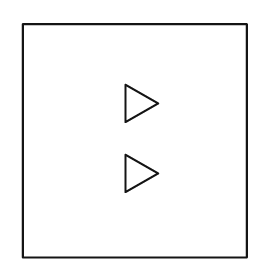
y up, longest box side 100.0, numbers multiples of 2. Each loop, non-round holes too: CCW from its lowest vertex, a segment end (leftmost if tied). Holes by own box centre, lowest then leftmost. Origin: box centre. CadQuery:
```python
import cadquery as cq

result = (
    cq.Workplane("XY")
    .moveTo(-48.0, -50.0)
    .lineTo(48.0, -50.0)
    .lineTo(48.0, 50.0)
    .lineTo(-48.0, 50.0)
    .close()
    .moveTo(-4.0, -22.0)
    .lineTo(10.0, -14.0)
    .lineTo(-4.0, -6.0)
    .close()
    .moveTo(-4.0, 8.0)
    .lineTo(10.0, 16.0)
    .lineTo(-4.0, 24.0)
    .close()
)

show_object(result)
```